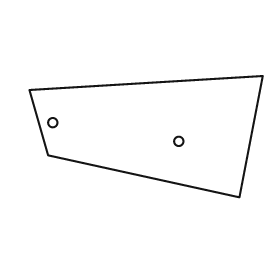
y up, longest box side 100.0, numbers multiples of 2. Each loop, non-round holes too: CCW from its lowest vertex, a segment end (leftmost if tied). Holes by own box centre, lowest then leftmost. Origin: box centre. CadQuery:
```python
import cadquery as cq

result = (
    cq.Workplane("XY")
    .moveTo(40.0, -26.0)
    .lineTo(50.0, 26.0)
    .lineTo(-50.0, 20.0)
    .lineTo(-42.0, -8.0)
    .close()
    .moveTo(14.0, -2.0)
    .circle(2.0)
    .moveTo(-40.0, 6.0)
    .circle(2.0)
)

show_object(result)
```